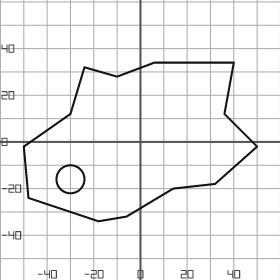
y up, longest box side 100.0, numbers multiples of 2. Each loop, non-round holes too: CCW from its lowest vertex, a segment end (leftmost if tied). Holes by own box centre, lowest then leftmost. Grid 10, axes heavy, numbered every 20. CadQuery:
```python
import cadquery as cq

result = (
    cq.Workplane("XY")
    .moveTo(-18.0, -34.0)
    .lineTo(-6.0, -32.0)
    .lineTo(14.0, -20.0)
    .lineTo(32.0, -18.0)
    .lineTo(50.0, -2.0)
    .lineTo(36.0, 12.0)
    .lineTo(40.0, 34.0)
    .lineTo(6.0, 34.0)
    .lineTo(-10.0, 28.0)
    .lineTo(-24.0, 32.0)
    .lineTo(-30.0, 12.0)
    .lineTo(-50.0, -2.0)
    .lineTo(-48.0, -24.0)
    .close()
    .moveTo(-30.0, -16.0)
    .circle(6.0)
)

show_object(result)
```